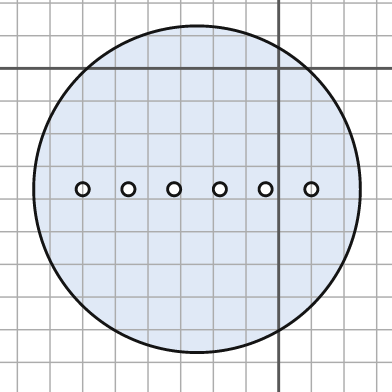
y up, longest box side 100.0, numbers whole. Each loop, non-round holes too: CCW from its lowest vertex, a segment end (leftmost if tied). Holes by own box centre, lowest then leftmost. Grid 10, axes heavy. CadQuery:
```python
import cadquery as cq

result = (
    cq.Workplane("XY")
    .moveTo(-25.0, -37.0)
    .circle(50.0)
    .moveTo(-60.0, -37.0)
    .circle(2.0)
    .moveTo(-46.0, -37.0)
    .circle(2.0)
    .moveTo(-32.0, -37.0)
    .circle(2.0)
    .moveTo(-18.0, -37.0)
    .circle(2.0)
    .moveTo(-4.0, -37.0)
    .circle(2.0)
    .moveTo(10.0, -37.0)
    .circle(2.0)
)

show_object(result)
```